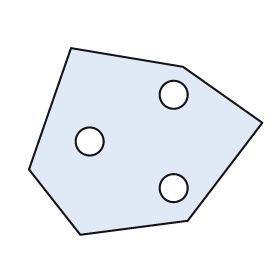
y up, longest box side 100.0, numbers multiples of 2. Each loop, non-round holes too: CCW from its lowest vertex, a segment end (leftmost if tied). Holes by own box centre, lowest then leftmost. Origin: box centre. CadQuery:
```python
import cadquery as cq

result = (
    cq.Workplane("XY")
    .moveTo(-28.0, -40.0)
    .lineTo(18.0, -34.0)
    .lineTo(50.0, 8.0)
    .lineTo(16.0, 32.0)
    .lineTo(-32.0, 40.0)
    .lineTo(-50.0, -12.0)
    .close()
    .moveTo(12.0, -20.0)
    .circle(6.0)
    .moveTo(-24.0, 0.0)
    .circle(6.0)
    .moveTo(12.0, 20.0)
    .circle(6.0)
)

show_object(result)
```